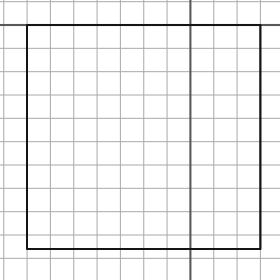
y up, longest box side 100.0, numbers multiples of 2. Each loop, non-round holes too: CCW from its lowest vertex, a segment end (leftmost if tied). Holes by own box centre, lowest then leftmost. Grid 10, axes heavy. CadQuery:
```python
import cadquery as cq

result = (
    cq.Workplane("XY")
    .moveTo(-70.0, -96.0)
    .lineTo(30.0, -96.0)
    .lineTo(30.0, 0.0)
    .lineTo(-70.0, 0.0)
    .close()
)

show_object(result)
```